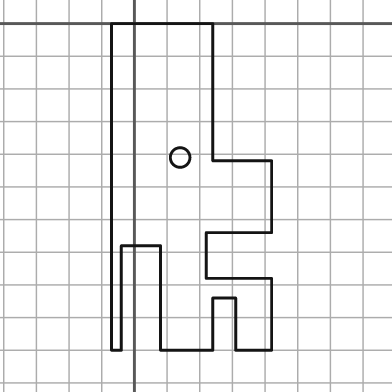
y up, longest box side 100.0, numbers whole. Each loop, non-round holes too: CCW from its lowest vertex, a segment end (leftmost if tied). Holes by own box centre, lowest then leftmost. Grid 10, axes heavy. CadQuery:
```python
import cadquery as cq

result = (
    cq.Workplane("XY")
    .moveTo(-7.0, -100.0)
    .lineTo(-4.0, -100.0)
    .lineTo(-4.0, -68.0)
    .lineTo(8.0, -68.0)
    .lineTo(8.0, -100.0)
    .lineTo(24.0, -100.0)
    .lineTo(24.0, -84.0)
    .lineTo(31.0, -84.0)
    .lineTo(31.0, -100.0)
    .lineTo(42.0, -100.0)
    .lineTo(42.0, -78.0)
    .lineTo(22.0, -78.0)
    .lineTo(22.0, -64.0)
    .lineTo(42.0, -64.0)
    .lineTo(42.0, -42.0)
    .lineTo(24.0, -42.0)
    .lineTo(24.0, 0.0)
    .lineTo(-7.0, 0.0)
    .close()
    .moveTo(14.0, -41.0)
    .circle(3.0)
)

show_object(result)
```